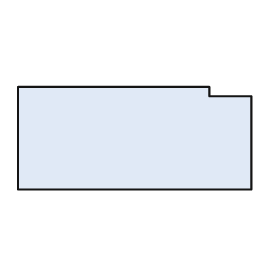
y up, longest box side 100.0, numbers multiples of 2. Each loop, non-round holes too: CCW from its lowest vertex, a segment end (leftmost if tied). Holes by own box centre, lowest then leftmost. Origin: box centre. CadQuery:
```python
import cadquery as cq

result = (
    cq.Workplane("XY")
    .moveTo(-50.0, -22.0)
    .lineTo(50.0, -22.0)
    .lineTo(50.0, 18.0)
    .lineTo(32.0, 18.0)
    .lineTo(32.0, 22.0)
    .lineTo(-50.0, 22.0)
    .close()
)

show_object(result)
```